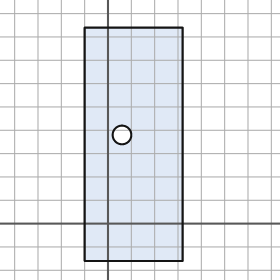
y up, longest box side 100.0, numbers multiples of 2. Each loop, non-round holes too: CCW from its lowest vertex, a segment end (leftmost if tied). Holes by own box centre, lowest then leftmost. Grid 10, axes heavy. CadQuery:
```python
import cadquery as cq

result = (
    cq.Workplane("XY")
    .moveTo(-10.0, -16.0)
    .lineTo(32.0, -16.0)
    .lineTo(32.0, 84.0)
    .lineTo(-10.0, 84.0)
    .close()
    .moveTo(6.0, 38.0)
    .circle(4.0)
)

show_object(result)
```